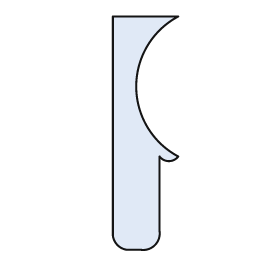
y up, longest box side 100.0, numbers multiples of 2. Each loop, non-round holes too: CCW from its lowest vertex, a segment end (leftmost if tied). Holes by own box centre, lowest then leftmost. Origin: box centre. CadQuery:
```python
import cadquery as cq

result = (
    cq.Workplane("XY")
    .moveTo(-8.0, -50.0)
    .lineTo(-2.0, -50.0)
    .threePointArc((4.0, -48.0), (6.0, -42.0))
    .lineTo(6.0, -10.0)
    .threePointArc((10.0, -12.0), (14.0, -10.0))
    .threePointArc((-4.0, 20.0), (14.0, 50.0))
    .lineTo(-14.0, 50.0)
    .lineTo(-14.0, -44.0)
    .threePointArc((-12.0, -48.0), (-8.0, -50.0))
    .close()
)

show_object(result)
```